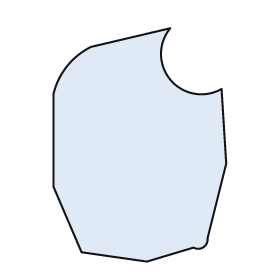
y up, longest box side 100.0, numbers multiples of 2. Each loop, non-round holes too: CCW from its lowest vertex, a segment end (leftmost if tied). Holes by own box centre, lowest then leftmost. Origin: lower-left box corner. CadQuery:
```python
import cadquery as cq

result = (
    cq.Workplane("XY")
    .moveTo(40.0, 0.0)
    .lineTo(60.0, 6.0)
    .threePointArc((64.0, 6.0), (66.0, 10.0))
    .lineTo(74.0, 42.0)
    .lineTo(72.0, 74.0)
    .threePointArc((50.0, 78.0), (50.0, 100.0))
    .lineTo(16.0, 92.0)
    .threePointArc((6.0, 84.0), (0.0, 72.0))
    .lineTo(0.0, 32.0)
    .lineTo(12.0, 4.0)
    .close()
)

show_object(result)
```